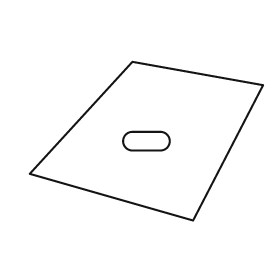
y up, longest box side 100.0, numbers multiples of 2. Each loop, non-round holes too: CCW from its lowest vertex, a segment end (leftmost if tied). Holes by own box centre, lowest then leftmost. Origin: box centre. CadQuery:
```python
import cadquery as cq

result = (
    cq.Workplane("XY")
    .moveTo(20.0, -34.0)
    .lineTo(50.0, 24.0)
    .lineTo(-6.0, 34.0)
    .lineTo(-50.0, -14.0)
    .close()
    .moveTo(-6.0, -4.0)
    .lineTo(6.0, -4.0)
    .threePointArc((10.0, 0.0), (6.0, 4.0))
    .lineTo(-6.0, 4.0)
    .threePointArc((-10.0, 0.0), (-6.0, -4.0))
    .close()
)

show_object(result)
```